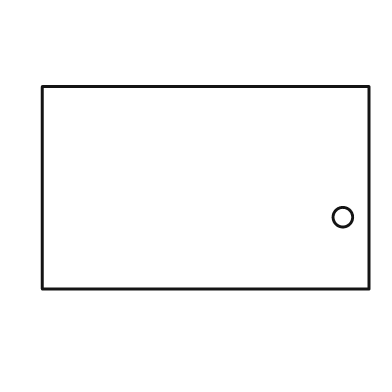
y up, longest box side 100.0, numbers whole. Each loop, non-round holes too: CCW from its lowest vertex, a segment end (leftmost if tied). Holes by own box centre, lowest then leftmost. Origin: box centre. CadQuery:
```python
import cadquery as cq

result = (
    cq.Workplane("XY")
    .moveTo(-50.0, -31.0)
    .lineTo(50.0, -31.0)
    .lineTo(50.0, 31.0)
    .lineTo(-50.0, 31.0)
    .close()
    .moveTo(42.0, -9.0)
    .circle(3.0)
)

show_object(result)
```